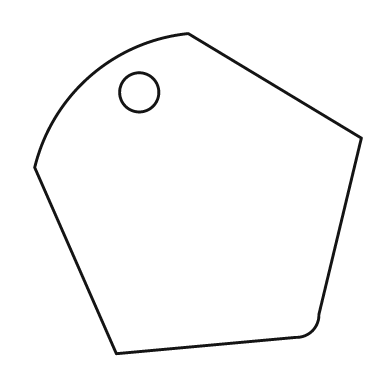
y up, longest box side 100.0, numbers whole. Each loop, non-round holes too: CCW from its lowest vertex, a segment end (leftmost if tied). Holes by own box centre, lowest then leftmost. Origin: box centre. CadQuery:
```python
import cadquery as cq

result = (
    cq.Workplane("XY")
    .moveTo(-25.0, -49.0)
    .lineTo(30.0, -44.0)
    .threePointArc((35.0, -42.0), (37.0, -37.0))
    .lineTo(50.0, 17.0)
    .lineTo(-3.0, 49.0)
    .threePointArc((-33.0, 36.0), (-50.0, 8.0))
    .close()
    .moveTo(-18.0, 31.0)
    .circle(6.0)
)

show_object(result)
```